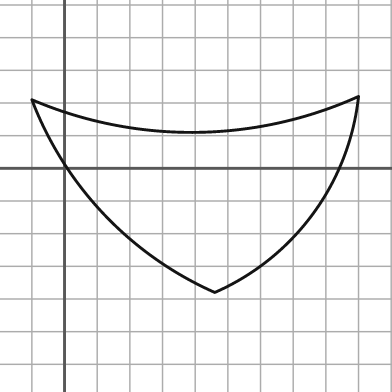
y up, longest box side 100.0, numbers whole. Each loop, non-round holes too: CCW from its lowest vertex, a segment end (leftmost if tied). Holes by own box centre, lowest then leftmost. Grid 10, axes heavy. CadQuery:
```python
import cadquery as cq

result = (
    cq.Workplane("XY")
    .moveTo(46.0, -38.0)
    .threePointArc((76.0, -14.0), (90.0, 22.0))
    .threePointArc((40.0, 11.0), (-10.0, 21.0))
    .threePointArc((12.0, -14.0), (46.0, -38.0))
    .close()
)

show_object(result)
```